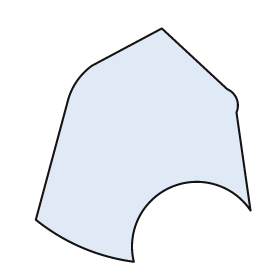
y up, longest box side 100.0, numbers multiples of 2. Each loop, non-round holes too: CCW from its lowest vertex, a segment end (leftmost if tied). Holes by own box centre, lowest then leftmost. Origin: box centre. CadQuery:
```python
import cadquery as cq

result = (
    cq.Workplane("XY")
    .moveTo(-4.0, -50.0)
    .threePointArc((12.0, -18.0), (46.0, -28.0))
    .lineTo(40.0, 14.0)
    .threePointArc((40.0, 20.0), (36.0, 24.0))
    .lineTo(8.0, 50.0)
    .lineTo(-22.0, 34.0)
    .threePointArc((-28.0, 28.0), (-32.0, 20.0))
    .lineTo(-46.0, -32.0)
    .threePointArc((-26.0, -44.0), (-4.0, -50.0))
    .close()
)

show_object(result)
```